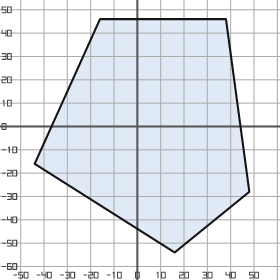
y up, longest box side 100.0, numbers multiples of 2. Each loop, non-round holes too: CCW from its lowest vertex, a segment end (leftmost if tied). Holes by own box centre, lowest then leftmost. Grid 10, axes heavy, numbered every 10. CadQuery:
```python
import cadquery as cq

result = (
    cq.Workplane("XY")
    .moveTo(16.0, -54.0)
    .lineTo(48.0, -28.0)
    .lineTo(38.0, 46.0)
    .lineTo(-16.0, 46.0)
    .lineTo(-44.0, -16.0)
    .close()
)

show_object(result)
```